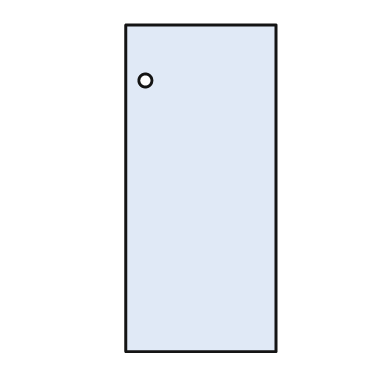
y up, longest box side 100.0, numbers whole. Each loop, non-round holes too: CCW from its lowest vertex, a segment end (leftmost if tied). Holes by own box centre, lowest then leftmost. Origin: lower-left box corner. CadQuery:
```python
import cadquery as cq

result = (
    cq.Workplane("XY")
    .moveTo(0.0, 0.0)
    .lineTo(46.0, 0.0)
    .lineTo(46.0, 100.0)
    .lineTo(0.0, 100.0)
    .close()
    .moveTo(6.0, 83.0)
    .circle(2.0)
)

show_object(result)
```